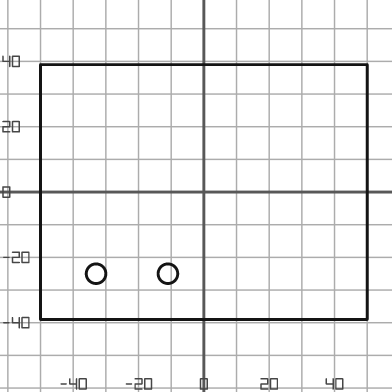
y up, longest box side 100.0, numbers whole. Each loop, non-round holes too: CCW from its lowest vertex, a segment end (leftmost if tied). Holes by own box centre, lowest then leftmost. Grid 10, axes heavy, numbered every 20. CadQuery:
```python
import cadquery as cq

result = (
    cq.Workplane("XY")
    .moveTo(-50.0, -39.0)
    .lineTo(50.0, -39.0)
    .lineTo(50.0, 39.0)
    .lineTo(-50.0, 39.0)
    .close()
    .moveTo(-33.0, -25.0)
    .circle(3.0)
    .moveTo(-11.0, -25.0)
    .circle(3.0)
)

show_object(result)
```